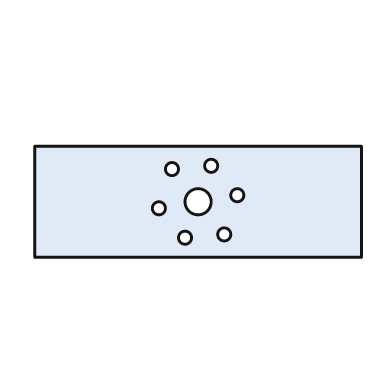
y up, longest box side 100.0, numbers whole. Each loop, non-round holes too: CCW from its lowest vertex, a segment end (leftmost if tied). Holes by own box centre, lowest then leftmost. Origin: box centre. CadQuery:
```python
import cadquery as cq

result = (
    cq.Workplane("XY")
    .moveTo(-50.0, -17.0)
    .lineTo(50.0, -17.0)
    .lineTo(50.0, 17.0)
    .lineTo(-50.0, 17.0)
    .close()
    .moveTo(-4.0, -11.0)
    .circle(2.0)
    .moveTo(8.0, -10.0)
    .circle(2.0)
    .moveTo(-12.0, -2.0)
    .circle(2.0)
    .moveTo(0.0, 0.0)
    .circle(4.0)
    .moveTo(12.0, 2.0)
    .circle(2.0)
    .moveTo(-8.0, 10.0)
    .circle(2.0)
    .moveTo(4.0, 11.0)
    .circle(2.0)
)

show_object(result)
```